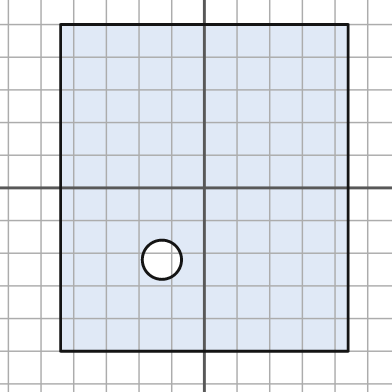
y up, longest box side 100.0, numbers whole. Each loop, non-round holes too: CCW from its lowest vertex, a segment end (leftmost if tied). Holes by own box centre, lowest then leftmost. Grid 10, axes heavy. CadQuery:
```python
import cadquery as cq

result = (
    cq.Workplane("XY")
    .moveTo(-44.0, -50.0)
    .lineTo(44.0, -50.0)
    .lineTo(44.0, 50.0)
    .lineTo(-44.0, 50.0)
    .close()
    .moveTo(-13.0, -22.0)
    .circle(6.0)
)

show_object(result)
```